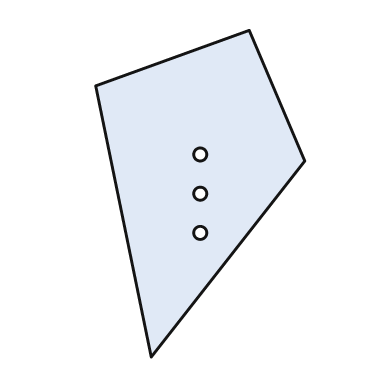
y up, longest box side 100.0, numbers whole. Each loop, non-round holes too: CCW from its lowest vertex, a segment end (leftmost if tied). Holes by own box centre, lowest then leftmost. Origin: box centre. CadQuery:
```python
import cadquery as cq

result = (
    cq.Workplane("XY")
    .moveTo(-15.0, -50.0)
    .lineTo(32.0, 10.0)
    .lineTo(15.0, 50.0)
    .lineTo(-32.0, 33.0)
    .close()
    .moveTo(0.0, -12.0)
    .circle(2.0)
    .moveTo(0.0, 0.0)
    .circle(2.0)
    .moveTo(0.0, 12.0)
    .circle(2.0)
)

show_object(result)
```